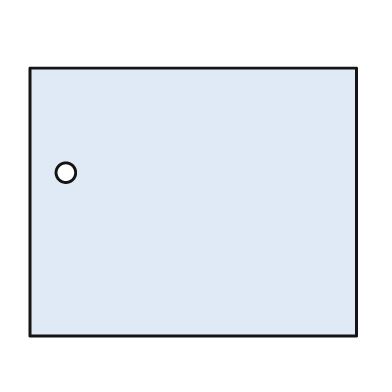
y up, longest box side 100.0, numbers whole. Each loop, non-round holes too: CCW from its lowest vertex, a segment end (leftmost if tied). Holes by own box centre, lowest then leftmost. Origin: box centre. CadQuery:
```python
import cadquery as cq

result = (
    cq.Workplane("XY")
    .moveTo(-50.0, -41.0)
    .lineTo(50.0, -41.0)
    .lineTo(50.0, 41.0)
    .lineTo(-50.0, 41.0)
    .close()
    .moveTo(-39.0, 9.0)
    .circle(3.0)
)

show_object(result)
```